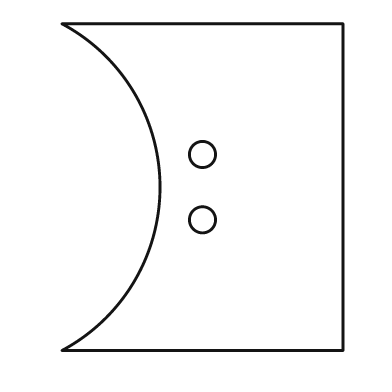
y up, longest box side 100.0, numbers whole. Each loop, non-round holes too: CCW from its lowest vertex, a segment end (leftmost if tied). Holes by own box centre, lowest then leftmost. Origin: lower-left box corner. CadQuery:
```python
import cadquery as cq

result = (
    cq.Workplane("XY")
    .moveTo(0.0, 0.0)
    .lineTo(86.0, 0.0)
    .lineTo(86.0, 100.0)
    .lineTo(0.0, 100.0)
    .threePointArc((30.0, 50.0), (0.0, 0.0))
    .close()
    .moveTo(43.0, 40.0)
    .circle(4.0)
    .moveTo(43.0, 60.0)
    .circle(4.0)
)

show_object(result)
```